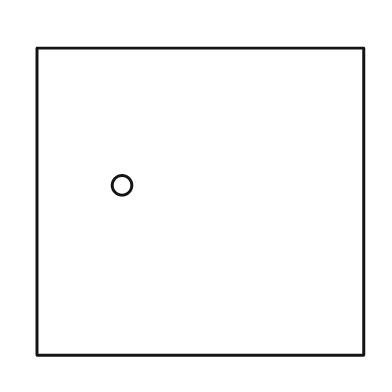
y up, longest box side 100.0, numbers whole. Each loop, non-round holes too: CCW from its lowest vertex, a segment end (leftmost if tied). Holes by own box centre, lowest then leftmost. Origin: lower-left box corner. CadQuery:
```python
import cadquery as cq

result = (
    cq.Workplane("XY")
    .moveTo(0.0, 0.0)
    .lineTo(100.0, 0.0)
    .lineTo(100.0, 94.0)
    .lineTo(0.0, 94.0)
    .close()
    .moveTo(26.0, 52.0)
    .circle(3.0)
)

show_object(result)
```